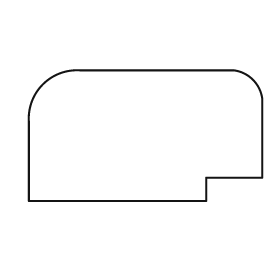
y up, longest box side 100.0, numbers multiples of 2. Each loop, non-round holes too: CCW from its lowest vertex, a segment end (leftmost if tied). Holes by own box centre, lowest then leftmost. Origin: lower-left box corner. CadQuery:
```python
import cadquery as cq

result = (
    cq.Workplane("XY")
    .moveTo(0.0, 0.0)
    .lineTo(76.0, 0.0)
    .lineTo(76.0, 10.0)
    .lineTo(100.0, 10.0)
    .lineTo(100.0, 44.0)
    .threePointArc((96.0, 52.0), (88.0, 56.0))
    .lineTo(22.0, 56.0)
    .threePointArc((6.0, 50.0), (0.0, 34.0))
    .close()
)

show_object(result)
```